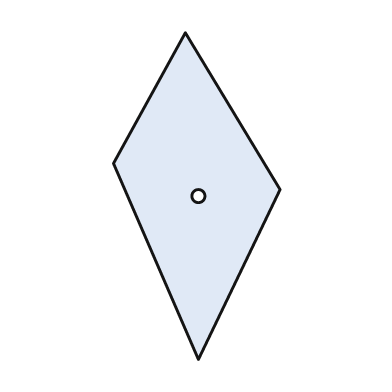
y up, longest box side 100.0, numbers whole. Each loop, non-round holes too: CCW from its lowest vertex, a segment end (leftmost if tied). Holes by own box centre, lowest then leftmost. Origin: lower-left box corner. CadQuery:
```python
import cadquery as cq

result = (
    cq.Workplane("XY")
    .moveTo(26.0, 0.0)
    .lineTo(51.0, 52.0)
    .lineTo(22.0, 100.0)
    .lineTo(0.0, 60.0)
    .close()
    .moveTo(26.0, 50.0)
    .circle(2.0)
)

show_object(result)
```